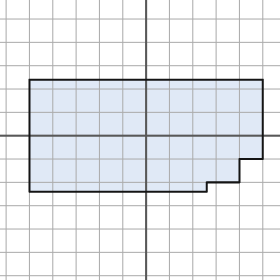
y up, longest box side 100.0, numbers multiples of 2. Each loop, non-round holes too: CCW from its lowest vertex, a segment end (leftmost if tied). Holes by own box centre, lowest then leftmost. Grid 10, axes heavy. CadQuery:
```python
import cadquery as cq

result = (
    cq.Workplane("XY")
    .moveTo(-50.0, -24.0)
    .lineTo(26.0, -24.0)
    .lineTo(26.0, -20.0)
    .lineTo(40.0, -20.0)
    .lineTo(40.0, -10.0)
    .lineTo(50.0, -10.0)
    .lineTo(50.0, 24.0)
    .lineTo(-50.0, 24.0)
    .close()
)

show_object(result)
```